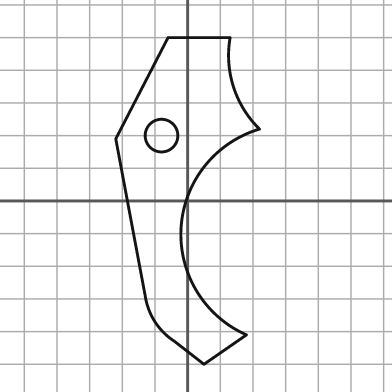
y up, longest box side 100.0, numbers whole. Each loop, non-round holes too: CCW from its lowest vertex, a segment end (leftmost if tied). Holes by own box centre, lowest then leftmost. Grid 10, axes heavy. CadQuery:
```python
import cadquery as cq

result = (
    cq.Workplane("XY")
    .moveTo(5.0, -50.0)
    .lineTo(18.0, -41.0)
    .threePointArc((-2.0, -8.0), (22.0, 22.0))
    .threePointArc((14.0, 35.0), (13.0, 50.0))
    .lineTo(-6.0, 50.0)
    .lineTo(-22.0, 19.0)
    .lineTo(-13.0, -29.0)
    .threePointArc((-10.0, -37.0), (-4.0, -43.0))
    .close()
    .moveTo(-8.0, 20.0)
    .circle(5.0)
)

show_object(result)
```